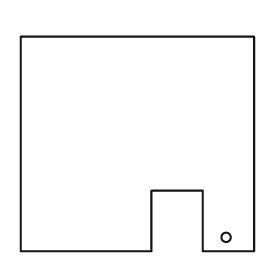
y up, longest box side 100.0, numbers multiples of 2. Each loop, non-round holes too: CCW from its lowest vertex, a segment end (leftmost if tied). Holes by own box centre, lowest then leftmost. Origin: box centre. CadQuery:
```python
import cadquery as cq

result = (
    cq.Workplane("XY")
    .moveTo(-50.0, -46.0)
    .lineTo(6.0, -46.0)
    .lineTo(6.0, -20.0)
    .lineTo(28.0, -20.0)
    .lineTo(28.0, -46.0)
    .lineTo(50.0, -46.0)
    .lineTo(50.0, 46.0)
    .lineTo(-50.0, 46.0)
    .close()
    .moveTo(38.0, -40.0)
    .circle(2.0)
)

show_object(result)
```